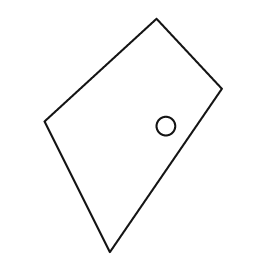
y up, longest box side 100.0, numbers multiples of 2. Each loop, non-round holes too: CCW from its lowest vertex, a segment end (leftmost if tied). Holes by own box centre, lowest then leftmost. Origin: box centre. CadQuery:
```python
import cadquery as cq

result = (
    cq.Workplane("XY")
    .moveTo(-10.0, -50.0)
    .lineTo(38.0, 20.0)
    .lineTo(10.0, 50.0)
    .lineTo(-38.0, 6.0)
    .close()
    .moveTo(14.0, 4.0)
    .circle(4.0)
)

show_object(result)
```